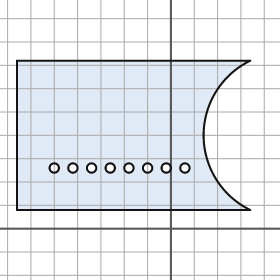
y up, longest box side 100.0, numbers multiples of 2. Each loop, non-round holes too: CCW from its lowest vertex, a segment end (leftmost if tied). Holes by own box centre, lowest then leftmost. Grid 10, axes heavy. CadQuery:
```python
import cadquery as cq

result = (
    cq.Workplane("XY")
    .moveTo(-66.0, 8.0)
    .lineTo(34.0, 8.0)
    .threePointArc((14.0, 40.0), (34.0, 72.0))
    .lineTo(-66.0, 72.0)
    .close()
    .moveTo(-50.0, 26.0)
    .circle(2.0)
    .moveTo(-42.0, 26.0)
    .circle(2.0)
    .moveTo(-34.0, 26.0)
    .circle(2.0)
    .moveTo(-26.0, 26.0)
    .circle(2.0)
    .moveTo(-18.0, 26.0)
    .circle(2.0)
    .moveTo(-10.0, 26.0)
    .circle(2.0)
    .moveTo(-2.0, 26.0)
    .circle(2.0)
    .moveTo(6.0, 26.0)
    .circle(2.0)
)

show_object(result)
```